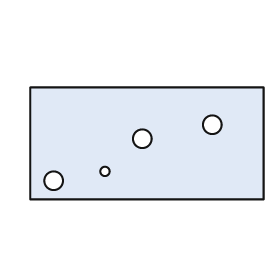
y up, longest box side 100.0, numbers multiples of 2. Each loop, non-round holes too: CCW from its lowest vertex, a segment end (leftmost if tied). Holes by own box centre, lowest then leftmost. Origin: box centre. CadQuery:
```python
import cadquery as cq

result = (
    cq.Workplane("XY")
    .moveTo(-50.0, -24.0)
    .lineTo(50.0, -24.0)
    .lineTo(50.0, 24.0)
    .lineTo(-50.0, 24.0)
    .close()
    .moveTo(-40.0, -16.0)
    .circle(4.0)
    .moveTo(-18.0, -12.0)
    .circle(2.0)
    .moveTo(-2.0, 2.0)
    .circle(4.0)
    .moveTo(28.0, 8.0)
    .circle(4.0)
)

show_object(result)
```